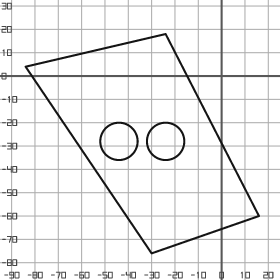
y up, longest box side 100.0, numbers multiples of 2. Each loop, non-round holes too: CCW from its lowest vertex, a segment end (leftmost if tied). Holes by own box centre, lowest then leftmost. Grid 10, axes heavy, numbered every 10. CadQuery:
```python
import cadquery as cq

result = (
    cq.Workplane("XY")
    .moveTo(-30.0, -76.0)
    .lineTo(16.0, -60.0)
    .lineTo(-24.0, 18.0)
    .lineTo(-84.0, 4.0)
    .close()
    .moveTo(-44.0, -28.0)
    .circle(8.0)
    .moveTo(-24.0, -28.0)
    .circle(8.0)
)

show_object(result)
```